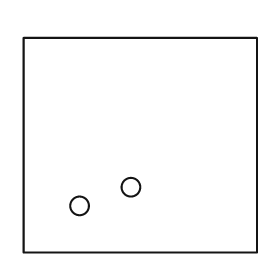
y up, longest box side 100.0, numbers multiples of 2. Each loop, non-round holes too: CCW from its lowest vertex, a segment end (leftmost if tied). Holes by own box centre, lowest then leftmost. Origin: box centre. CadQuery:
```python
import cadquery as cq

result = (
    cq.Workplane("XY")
    .moveTo(-50.0, -46.0)
    .lineTo(50.0, -46.0)
    .lineTo(50.0, 46.0)
    .lineTo(-50.0, 46.0)
    .close()
    .moveTo(-26.0, -26.0)
    .circle(4.0)
    .moveTo(-4.0, -18.0)
    .circle(4.0)
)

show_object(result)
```